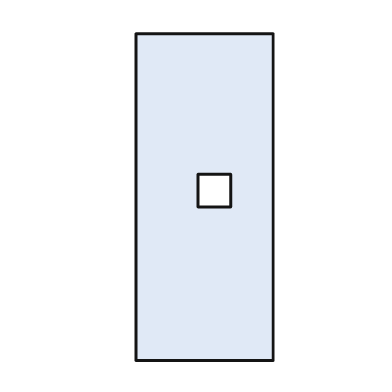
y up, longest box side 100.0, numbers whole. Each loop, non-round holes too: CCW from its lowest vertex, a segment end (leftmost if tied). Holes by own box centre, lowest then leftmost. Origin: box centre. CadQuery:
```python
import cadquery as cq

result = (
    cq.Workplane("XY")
    .moveTo(-21.0, -50.0)
    .lineTo(21.0, -50.0)
    .lineTo(21.0, 50.0)
    .lineTo(-21.0, 50.0)
    .close()
    .moveTo(-2.0, -3.0)
    .lineTo(8.0, -3.0)
    .lineTo(8.0, 7.0)
    .lineTo(-2.0, 7.0)
    .close()
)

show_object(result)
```